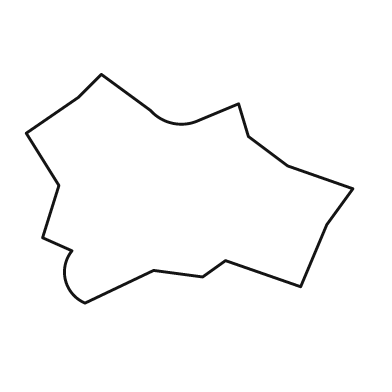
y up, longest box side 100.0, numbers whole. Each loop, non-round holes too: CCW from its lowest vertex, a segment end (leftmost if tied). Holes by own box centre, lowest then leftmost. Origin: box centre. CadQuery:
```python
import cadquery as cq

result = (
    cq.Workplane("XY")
    .moveTo(-32.0, -35.0)
    .lineTo(-11.0, -25.0)
    .lineTo(4.0, -27.0)
    .lineTo(11.0, -22.0)
    .lineTo(34.0, -30.0)
    .lineTo(42.0, -11.0)
    .lineTo(50.0, 0.0)
    .lineTo(30.0, 7.0)
    .lineTo(18.0, 16.0)
    .lineTo(15.0, 26.0)
    .lineTo(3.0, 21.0)
    .threePointArc((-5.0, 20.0), (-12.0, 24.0))
    .lineTo(-27.0, 35.0)
    .lineTo(-34.0, 28.0)
    .lineTo(-50.0, 17.0)
    .lineTo(-40.0, 1.0)
    .lineTo(-45.0, -15.0)
    .lineTo(-36.0, -19.0)
    .threePointArc((-38.0, -28.0), (-32.0, -35.0))
    .close()
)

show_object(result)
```